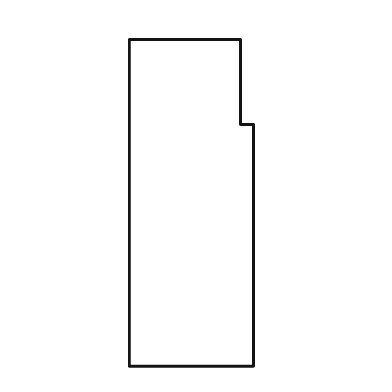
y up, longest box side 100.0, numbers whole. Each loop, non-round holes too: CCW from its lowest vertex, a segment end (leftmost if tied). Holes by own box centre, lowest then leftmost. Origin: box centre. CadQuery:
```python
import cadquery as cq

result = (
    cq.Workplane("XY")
    .moveTo(-19.0, -50.0)
    .lineTo(19.0, -50.0)
    .lineTo(19.0, 24.0)
    .lineTo(15.0, 24.0)
    .lineTo(15.0, 50.0)
    .lineTo(-19.0, 50.0)
    .close()
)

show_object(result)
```